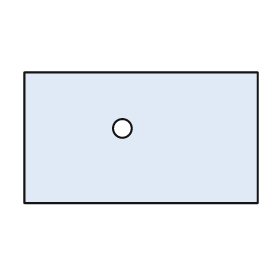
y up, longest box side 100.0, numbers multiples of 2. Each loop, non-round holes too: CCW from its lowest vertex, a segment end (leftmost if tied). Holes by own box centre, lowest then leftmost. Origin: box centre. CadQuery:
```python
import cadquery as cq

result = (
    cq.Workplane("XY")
    .moveTo(-50.0, -28.0)
    .lineTo(50.0, -28.0)
    .lineTo(50.0, 28.0)
    .lineTo(-50.0, 28.0)
    .close()
    .moveTo(-8.0, 4.0)
    .circle(4.0)
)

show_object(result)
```